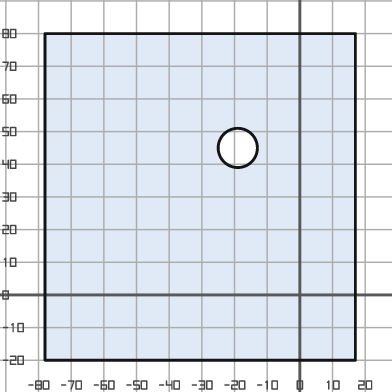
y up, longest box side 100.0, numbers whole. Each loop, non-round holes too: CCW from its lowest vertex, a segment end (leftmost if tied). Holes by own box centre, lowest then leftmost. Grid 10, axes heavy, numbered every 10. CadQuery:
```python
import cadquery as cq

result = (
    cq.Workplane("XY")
    .moveTo(-78.0, -20.0)
    .lineTo(17.0, -20.0)
    .lineTo(17.0, 80.0)
    .lineTo(-78.0, 80.0)
    .close()
    .moveTo(-19.0, 45.0)
    .circle(6.0)
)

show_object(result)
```